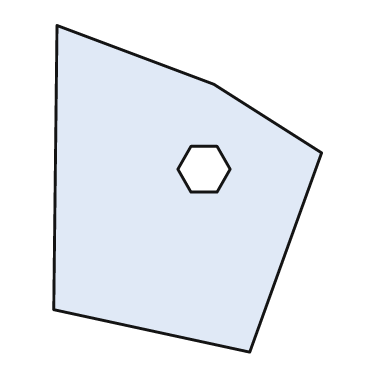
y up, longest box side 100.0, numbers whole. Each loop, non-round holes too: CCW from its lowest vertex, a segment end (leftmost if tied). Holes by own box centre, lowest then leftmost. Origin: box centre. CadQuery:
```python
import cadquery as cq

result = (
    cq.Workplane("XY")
    .moveTo(19.0, -50.0)
    .lineTo(41.0, 11.0)
    .lineTo(8.0, 32.0)
    .lineTo(-40.0, 50.0)
    .lineTo(-41.0, -37.0)
    .close()
    .moveTo(1.0, -1.0)
    .lineTo(9.0, -1.0)
    .lineTo(13.0, 6.0)
    .lineTo(9.0, 13.0)
    .lineTo(1.0, 13.0)
    .lineTo(-3.0, 6.0)
    .close()
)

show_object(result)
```